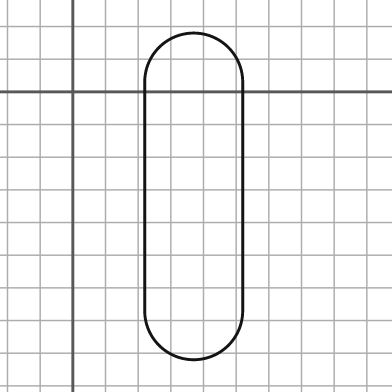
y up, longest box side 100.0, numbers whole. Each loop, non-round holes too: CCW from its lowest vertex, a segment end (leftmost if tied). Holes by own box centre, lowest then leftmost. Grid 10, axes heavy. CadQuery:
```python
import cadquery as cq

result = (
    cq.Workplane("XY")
    .moveTo(22.0, -67.0)
    .threePointArc((37.0, -82.0), (52.0, -67.0))
    .lineTo(52.0, 3.0)
    .threePointArc((37.0, 18.0), (22.0, 3.0))
    .close()
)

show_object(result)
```